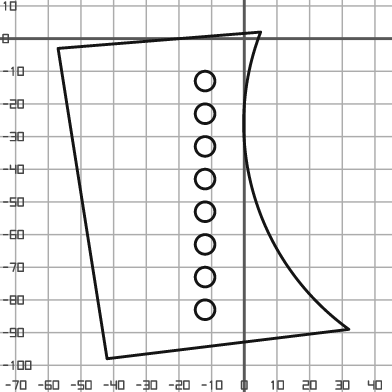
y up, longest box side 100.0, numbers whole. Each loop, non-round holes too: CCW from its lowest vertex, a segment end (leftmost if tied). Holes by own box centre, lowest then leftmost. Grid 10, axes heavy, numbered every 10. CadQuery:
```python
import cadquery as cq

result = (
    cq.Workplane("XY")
    .moveTo(-42.0, -98.0)
    .lineTo(32.0, -89.0)
    .threePointArc((3.0, -48.0), (5.0, 2.0))
    .lineTo(-57.0, -3.0)
    .close()
    .moveTo(-12.0, -83.0)
    .circle(3.0)
    .moveTo(-12.0, -73.0)
    .circle(3.0)
    .moveTo(-12.0, -63.0)
    .circle(3.0)
    .moveTo(-12.0, -53.0)
    .circle(3.0)
    .moveTo(-12.0, -43.0)
    .circle(3.0)
    .moveTo(-12.0, -33.0)
    .circle(3.0)
    .moveTo(-12.0, -23.0)
    .circle(3.0)
    .moveTo(-12.0, -13.0)
    .circle(3.0)
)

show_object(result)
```